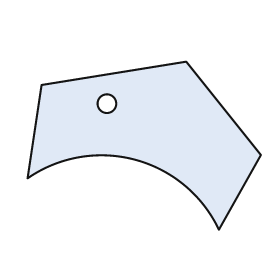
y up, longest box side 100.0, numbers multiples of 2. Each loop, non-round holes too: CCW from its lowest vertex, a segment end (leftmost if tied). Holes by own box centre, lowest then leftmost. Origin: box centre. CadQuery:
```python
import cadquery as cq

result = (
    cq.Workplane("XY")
    .moveTo(32.0, -36.0)
    .lineTo(50.0, -4.0)
    .lineTo(18.0, 36.0)
    .lineTo(-44.0, 26.0)
    .lineTo(-50.0, -14.0)
    .threePointArc((-4.0, -6.0), (32.0, -36.0))
    .close()
    .moveTo(-16.0, 18.0)
    .circle(4.0)
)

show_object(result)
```